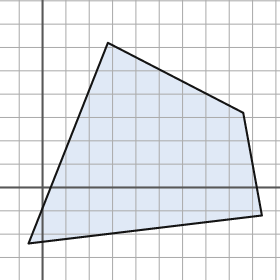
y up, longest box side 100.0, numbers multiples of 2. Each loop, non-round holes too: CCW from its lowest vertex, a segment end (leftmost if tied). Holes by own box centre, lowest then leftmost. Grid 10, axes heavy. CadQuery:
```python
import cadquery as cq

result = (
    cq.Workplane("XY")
    .moveTo(-6.0, -24.0)
    .lineTo(94.0, -12.0)
    .lineTo(86.0, 32.0)
    .lineTo(28.0, 62.0)
    .close()
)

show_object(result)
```